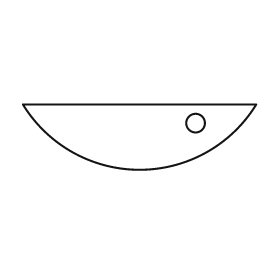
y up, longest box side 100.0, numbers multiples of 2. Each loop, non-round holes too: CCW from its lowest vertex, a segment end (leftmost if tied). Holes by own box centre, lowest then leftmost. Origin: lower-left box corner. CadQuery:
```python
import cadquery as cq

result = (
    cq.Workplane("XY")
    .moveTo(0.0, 28.0)
    .threePointArc((50.0, 0.0), (100.0, 28.0))
    .close()
    .moveTo(74.0, 20.0)
    .circle(4.0)
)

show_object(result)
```